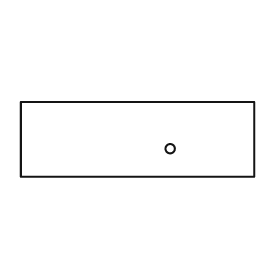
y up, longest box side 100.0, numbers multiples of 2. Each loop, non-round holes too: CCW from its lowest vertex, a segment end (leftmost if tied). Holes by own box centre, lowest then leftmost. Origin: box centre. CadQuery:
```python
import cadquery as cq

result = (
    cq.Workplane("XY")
    .moveTo(-50.0, -16.0)
    .lineTo(50.0, -16.0)
    .lineTo(50.0, 16.0)
    .lineTo(-50.0, 16.0)
    .close()
    .moveTo(14.0, -4.0)
    .circle(2.0)
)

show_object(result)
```